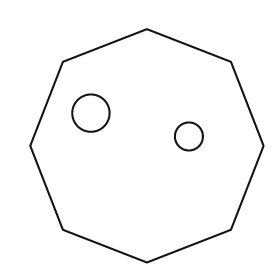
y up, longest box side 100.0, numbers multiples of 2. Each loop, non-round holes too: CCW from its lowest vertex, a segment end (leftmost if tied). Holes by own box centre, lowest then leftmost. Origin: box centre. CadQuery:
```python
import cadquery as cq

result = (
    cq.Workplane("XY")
    .moveTo(0.0, -50.0)
    .lineTo(36.0, -36.0)
    .lineTo(50.0, 0.0)
    .lineTo(36.0, 36.0)
    .lineTo(0.0, 50.0)
    .lineTo(-36.0, 36.0)
    .lineTo(-50.0, 0.0)
    .lineTo(-36.0, -36.0)
    .close()
    .moveTo(18.0, 4.0)
    .circle(6.0)
    .moveTo(-24.0, 14.0)
    .circle(8.0)
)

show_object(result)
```